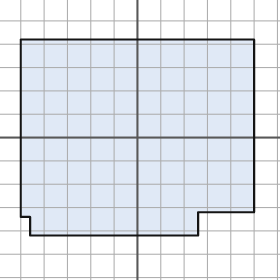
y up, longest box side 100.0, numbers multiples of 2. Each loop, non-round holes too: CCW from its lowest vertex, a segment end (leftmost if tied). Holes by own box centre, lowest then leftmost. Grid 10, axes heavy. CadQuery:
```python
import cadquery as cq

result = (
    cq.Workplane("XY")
    .moveTo(-46.0, -42.0)
    .lineTo(26.0, -42.0)
    .lineTo(26.0, -32.0)
    .lineTo(50.0, -32.0)
    .lineTo(50.0, 42.0)
    .lineTo(-50.0, 42.0)
    .lineTo(-50.0, -34.0)
    .lineTo(-46.0, -34.0)
    .close()
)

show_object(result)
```